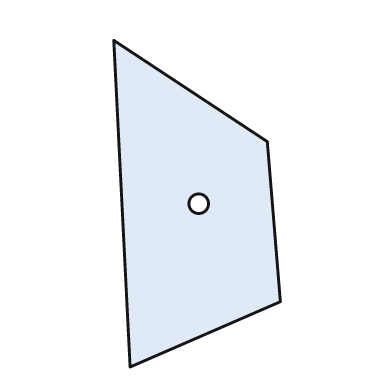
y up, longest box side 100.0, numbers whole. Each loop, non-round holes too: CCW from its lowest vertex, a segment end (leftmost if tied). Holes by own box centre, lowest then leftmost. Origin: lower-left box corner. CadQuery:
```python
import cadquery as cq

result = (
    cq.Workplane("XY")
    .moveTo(5.0, 0.0)
    .lineTo(51.0, 20.0)
    .lineTo(47.0, 69.0)
    .lineTo(0.0, 100.0)
    .close()
    .moveTo(26.0, 50.0)
    .circle(3.0)
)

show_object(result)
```